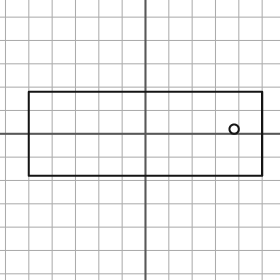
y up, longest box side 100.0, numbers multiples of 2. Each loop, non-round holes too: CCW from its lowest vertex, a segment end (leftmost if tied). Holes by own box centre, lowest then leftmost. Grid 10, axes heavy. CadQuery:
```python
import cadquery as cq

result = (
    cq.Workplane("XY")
    .moveTo(-50.0, -18.0)
    .lineTo(50.0, -18.0)
    .lineTo(50.0, 18.0)
    .lineTo(-50.0, 18.0)
    .close()
    .moveTo(38.0, 2.0)
    .circle(2.0)
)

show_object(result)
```